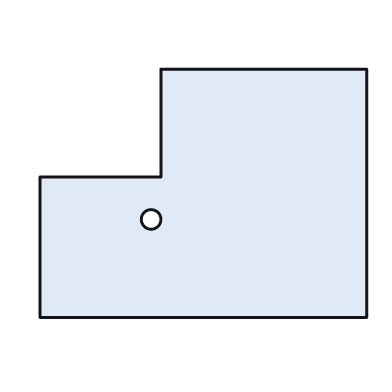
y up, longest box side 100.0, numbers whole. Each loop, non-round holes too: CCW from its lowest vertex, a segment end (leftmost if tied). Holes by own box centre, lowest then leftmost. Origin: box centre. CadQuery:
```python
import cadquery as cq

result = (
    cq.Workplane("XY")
    .moveTo(-50.0, -38.0)
    .lineTo(50.0, -38.0)
    .lineTo(50.0, 38.0)
    .lineTo(-13.0, 38.0)
    .lineTo(-13.0, 5.0)
    .lineTo(-50.0, 5.0)
    .close()
    .moveTo(-16.0, -8.0)
    .circle(3.0)
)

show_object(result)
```